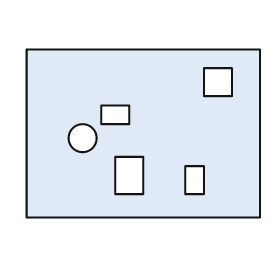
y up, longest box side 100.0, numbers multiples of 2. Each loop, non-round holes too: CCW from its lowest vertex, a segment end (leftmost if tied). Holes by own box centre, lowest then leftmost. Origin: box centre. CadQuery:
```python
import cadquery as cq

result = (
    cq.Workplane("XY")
    .moveTo(-50.0, -36.0)
    .lineTo(50.0, -36.0)
    .lineTo(50.0, 36.0)
    .lineTo(-50.0, 36.0)
    .close()
    .moveTo(18.0, -26.0)
    .lineTo(26.0, -26.0)
    .lineTo(26.0, -14.0)
    .lineTo(18.0, -14.0)
    .close()
    .moveTo(-12.0, -26.0)
    .lineTo(0.0, -26.0)
    .lineTo(0.0, -10.0)
    .lineTo(-12.0, -10.0)
    .close()
    .moveTo(-26.0, -2.0)
    .circle(6.0)
    .moveTo(-18.0, 4.0)
    .lineTo(-6.0, 4.0)
    .lineTo(-6.0, 12.0)
    .lineTo(-18.0, 12.0)
    .close()
    .moveTo(26.0, 16.0)
    .lineTo(38.0, 16.0)
    .lineTo(38.0, 28.0)
    .lineTo(26.0, 28.0)
    .close()
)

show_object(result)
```